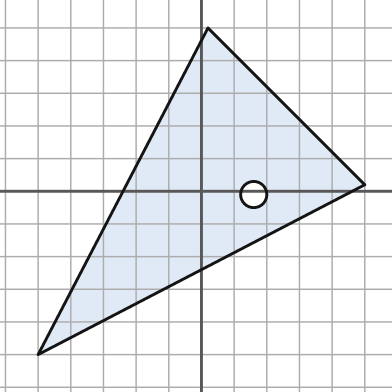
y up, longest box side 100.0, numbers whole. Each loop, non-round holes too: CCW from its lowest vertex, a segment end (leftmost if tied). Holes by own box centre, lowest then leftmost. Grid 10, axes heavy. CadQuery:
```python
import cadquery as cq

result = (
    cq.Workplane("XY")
    .moveTo(-50.0, -50.0)
    .lineTo(50.0, 2.0)
    .lineTo(2.0, 50.0)
    .close()
    .moveTo(16.0, -1.0)
    .circle(4.0)
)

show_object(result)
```